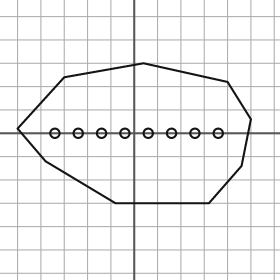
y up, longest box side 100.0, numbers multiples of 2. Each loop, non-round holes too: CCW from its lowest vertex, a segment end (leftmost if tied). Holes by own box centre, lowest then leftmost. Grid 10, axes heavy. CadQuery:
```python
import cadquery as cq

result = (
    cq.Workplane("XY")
    .moveTo(-8.0, -30.0)
    .lineTo(32.0, -30.0)
    .lineTo(46.0, -14.0)
    .lineTo(50.0, 6.0)
    .lineTo(40.0, 22.0)
    .lineTo(4.0, 30.0)
    .lineTo(-30.0, 24.0)
    .lineTo(-50.0, 2.0)
    .lineTo(-38.0, -12.0)
    .close()
    .moveTo(-34.0, 0.0)
    .circle(2.0)
    .moveTo(-24.0, 0.0)
    .circle(2.0)
    .moveTo(-14.0, 0.0)
    .circle(2.0)
    .moveTo(-4.0, 0.0)
    .circle(2.0)
    .moveTo(6.0, 0.0)
    .circle(2.0)
    .moveTo(16.0, 0.0)
    .circle(2.0)
    .moveTo(26.0, 0.0)
    .circle(2.0)
    .moveTo(36.0, 0.0)
    .circle(2.0)
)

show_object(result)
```